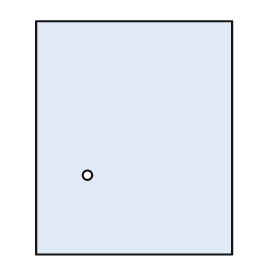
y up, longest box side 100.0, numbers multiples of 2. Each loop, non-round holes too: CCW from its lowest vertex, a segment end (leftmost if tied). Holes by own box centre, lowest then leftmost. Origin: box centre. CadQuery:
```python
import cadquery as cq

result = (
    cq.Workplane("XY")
    .moveTo(-42.0, -50.0)
    .lineTo(42.0, -50.0)
    .lineTo(42.0, 50.0)
    .lineTo(-42.0, 50.0)
    .close()
    .moveTo(-20.0, -16.0)
    .circle(2.0)
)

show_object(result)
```